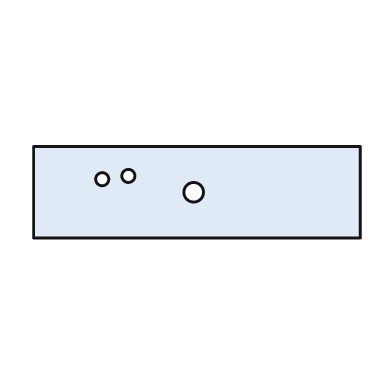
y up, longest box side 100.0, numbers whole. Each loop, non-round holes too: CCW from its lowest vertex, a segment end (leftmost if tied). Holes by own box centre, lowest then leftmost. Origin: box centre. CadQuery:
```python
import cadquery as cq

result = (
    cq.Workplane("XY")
    .moveTo(-50.0, -14.0)
    .lineTo(50.0, -14.0)
    .lineTo(50.0, 14.0)
    .lineTo(-50.0, 14.0)
    .close()
    .moveTo(-1.0, 0.0)
    .circle(3.0)
    .moveTo(-29.0, 4.0)
    .circle(2.0)
    .moveTo(-21.0, 5.0)
    .circle(2.0)
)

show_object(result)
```